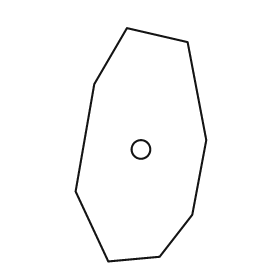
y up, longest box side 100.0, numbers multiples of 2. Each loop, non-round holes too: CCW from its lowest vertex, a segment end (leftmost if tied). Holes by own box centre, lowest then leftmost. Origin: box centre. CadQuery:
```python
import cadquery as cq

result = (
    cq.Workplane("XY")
    .moveTo(-14.0, -50.0)
    .lineTo(8.0, -48.0)
    .lineTo(22.0, -30.0)
    .lineTo(28.0, 2.0)
    .lineTo(20.0, 44.0)
    .lineTo(-6.0, 50.0)
    .lineTo(-20.0, 26.0)
    .lineTo(-28.0, -20.0)
    .close()
    .moveTo(0.0, -2.0)
    .circle(4.0)
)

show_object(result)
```